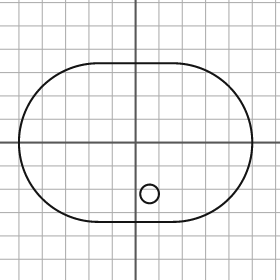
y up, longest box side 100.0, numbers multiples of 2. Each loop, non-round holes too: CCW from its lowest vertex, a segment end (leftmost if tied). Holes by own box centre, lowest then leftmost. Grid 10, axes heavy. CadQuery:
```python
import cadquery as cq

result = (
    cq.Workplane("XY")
    .moveTo(-16.0, -34.0)
    .lineTo(16.0, -34.0)
    .threePointArc((50.0, 0.0), (16.0, 34.0))
    .lineTo(-16.0, 34.0)
    .threePointArc((-50.0, 0.0), (-16.0, -34.0))
    .close()
    .moveTo(6.0, -22.0)
    .circle(4.0)
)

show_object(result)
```